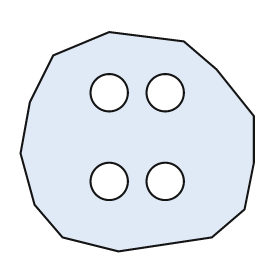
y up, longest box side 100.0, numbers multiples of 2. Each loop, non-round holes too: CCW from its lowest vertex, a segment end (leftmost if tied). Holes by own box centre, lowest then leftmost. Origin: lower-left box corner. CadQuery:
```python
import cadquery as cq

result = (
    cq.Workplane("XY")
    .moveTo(42.0, 0.0)
    .lineTo(82.0, 6.0)
    .lineTo(96.0, 18.0)
    .lineTo(100.0, 38.0)
    .lineTo(100.0, 58.0)
    .lineTo(84.0, 78.0)
    .lineTo(70.0, 90.0)
    .lineTo(38.0, 94.0)
    .lineTo(14.0, 84.0)
    .lineTo(4.0, 64.0)
    .lineTo(0.0, 42.0)
    .lineTo(6.0, 20.0)
    .lineTo(18.0, 6.0)
    .close()
    .moveTo(38.0, 30.0)
    .circle(8.0)
    .moveTo(62.0, 30.0)
    .circle(8.0)
    .moveTo(38.0, 68.0)
    .circle(8.0)
    .moveTo(62.0, 68.0)
    .circle(8.0)
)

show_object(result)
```